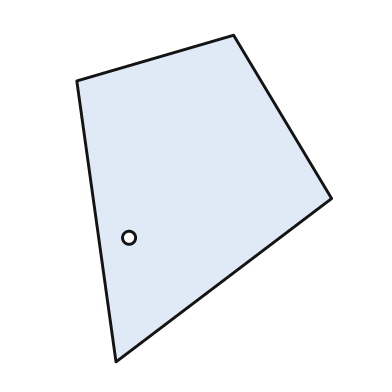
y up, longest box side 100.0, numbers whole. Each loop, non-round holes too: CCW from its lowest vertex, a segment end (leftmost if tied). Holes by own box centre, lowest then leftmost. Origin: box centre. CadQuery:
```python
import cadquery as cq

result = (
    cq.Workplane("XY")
    .moveTo(-27.0, -50.0)
    .lineTo(39.0, 0.0)
    .lineTo(9.0, 50.0)
    .lineTo(-39.0, 36.0)
    .close()
    .moveTo(-23.0, -12.0)
    .circle(2.0)
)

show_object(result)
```